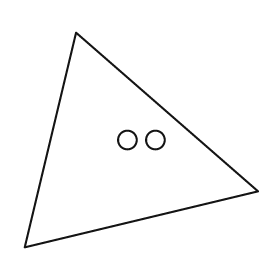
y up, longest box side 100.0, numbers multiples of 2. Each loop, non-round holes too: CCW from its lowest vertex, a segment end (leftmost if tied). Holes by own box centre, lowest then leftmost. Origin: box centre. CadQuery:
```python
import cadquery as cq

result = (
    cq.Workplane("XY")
    .moveTo(-50.0, -46.0)
    .lineTo(50.0, -22.0)
    .lineTo(-28.0, 46.0)
    .close()
    .moveTo(-6.0, 0.0)
    .circle(4.0)
    .moveTo(6.0, 0.0)
    .circle(4.0)
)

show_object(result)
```